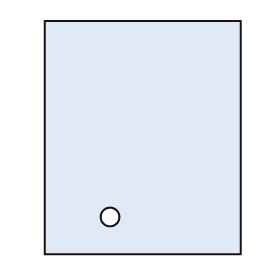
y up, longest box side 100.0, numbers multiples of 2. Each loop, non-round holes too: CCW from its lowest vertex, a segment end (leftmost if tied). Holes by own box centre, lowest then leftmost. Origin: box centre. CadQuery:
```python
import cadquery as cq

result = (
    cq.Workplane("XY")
    .moveTo(-42.0, -50.0)
    .lineTo(42.0, -50.0)
    .lineTo(42.0, 50.0)
    .lineTo(-42.0, 50.0)
    .close()
    .moveTo(-14.0, -34.0)
    .circle(4.0)
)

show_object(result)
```